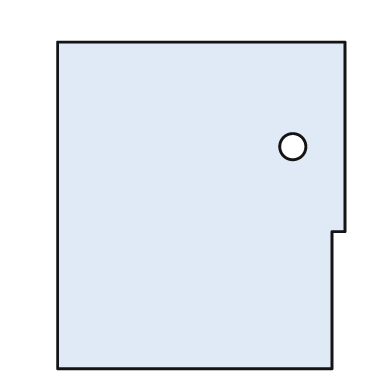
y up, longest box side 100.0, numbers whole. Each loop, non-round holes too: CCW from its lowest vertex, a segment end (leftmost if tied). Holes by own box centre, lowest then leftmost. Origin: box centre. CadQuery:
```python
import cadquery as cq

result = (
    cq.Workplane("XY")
    .moveTo(-44.0, -50.0)
    .lineTo(40.0, -50.0)
    .lineTo(40.0, -8.0)
    .lineTo(44.0, -8.0)
    .lineTo(44.0, 50.0)
    .lineTo(-44.0, 50.0)
    .close()
    .moveTo(28.0, 18.0)
    .circle(4.0)
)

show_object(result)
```